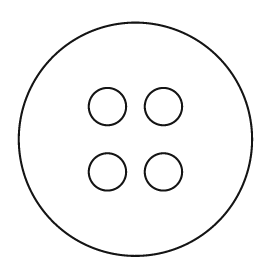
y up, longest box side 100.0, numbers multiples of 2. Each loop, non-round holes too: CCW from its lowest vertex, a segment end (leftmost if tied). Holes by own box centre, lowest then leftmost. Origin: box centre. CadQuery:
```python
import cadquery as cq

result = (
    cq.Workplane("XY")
    .moveTo(0.0, 0.0)
    .circle(50.0)
    .moveTo(-12.0, -14.0)
    .circle(8.0)
    .moveTo(12.0, -14.0)
    .circle(8.0)
    .moveTo(-12.0, 14.0)
    .circle(8.0)
    .moveTo(12.0, 14.0)
    .circle(8.0)
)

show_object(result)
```